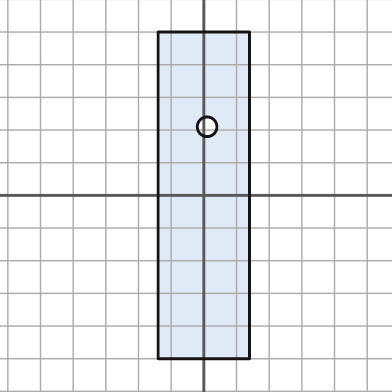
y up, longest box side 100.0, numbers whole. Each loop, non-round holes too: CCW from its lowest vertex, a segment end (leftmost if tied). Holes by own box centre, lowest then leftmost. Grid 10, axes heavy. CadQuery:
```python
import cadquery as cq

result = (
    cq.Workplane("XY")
    .moveTo(-14.0, -50.0)
    .lineTo(14.0, -50.0)
    .lineTo(14.0, 50.0)
    .lineTo(-14.0, 50.0)
    .close()
    .moveTo(1.0, 21.0)
    .circle(3.0)
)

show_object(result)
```